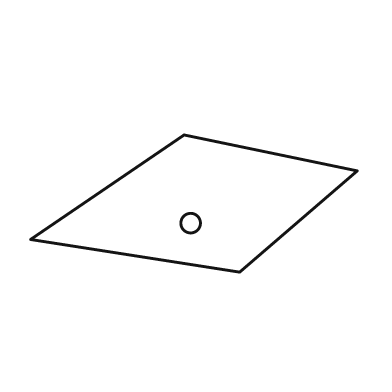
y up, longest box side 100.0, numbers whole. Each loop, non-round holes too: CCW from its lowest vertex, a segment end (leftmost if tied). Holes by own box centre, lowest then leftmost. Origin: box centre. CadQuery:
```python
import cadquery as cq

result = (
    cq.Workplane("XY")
    .moveTo(14.0, -21.0)
    .lineTo(50.0, 10.0)
    .lineTo(-3.0, 21.0)
    .lineTo(-50.0, -11.0)
    .close()
    .moveTo(-1.0, -6.0)
    .circle(3.0)
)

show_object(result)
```